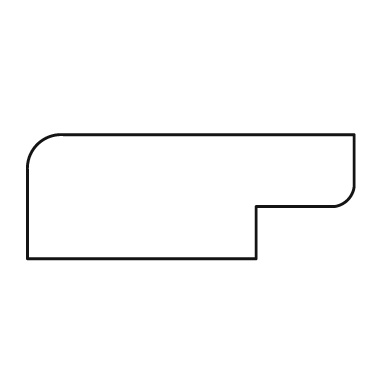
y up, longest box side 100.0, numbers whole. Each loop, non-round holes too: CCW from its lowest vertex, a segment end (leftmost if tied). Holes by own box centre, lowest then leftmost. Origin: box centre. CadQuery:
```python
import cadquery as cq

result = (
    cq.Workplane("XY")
    .moveTo(-50.0, -19.0)
    .lineTo(20.0, -19.0)
    .lineTo(20.0, -3.0)
    .lineTo(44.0, -3.0)
    .threePointArc((48.0, -1.0), (50.0, 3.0))
    .lineTo(50.0, 19.0)
    .lineTo(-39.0, 19.0)
    .threePointArc((-47.0, 16.0), (-50.0, 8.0))
    .close()
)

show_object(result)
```